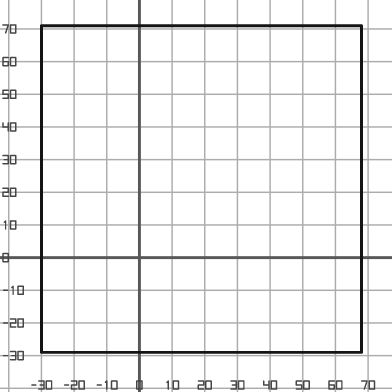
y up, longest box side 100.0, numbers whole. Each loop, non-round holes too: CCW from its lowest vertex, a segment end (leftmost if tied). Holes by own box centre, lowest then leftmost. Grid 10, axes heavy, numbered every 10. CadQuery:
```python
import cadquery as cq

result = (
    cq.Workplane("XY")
    .moveTo(-30.0, -29.0)
    .lineTo(68.0, -29.0)
    .lineTo(68.0, 71.0)
    .lineTo(-30.0, 71.0)
    .close()
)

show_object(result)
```